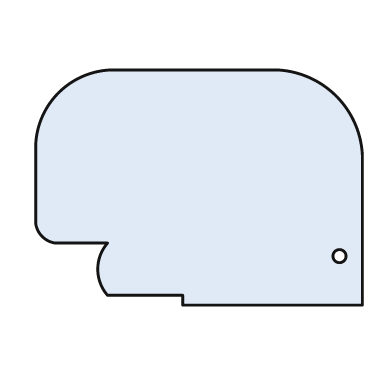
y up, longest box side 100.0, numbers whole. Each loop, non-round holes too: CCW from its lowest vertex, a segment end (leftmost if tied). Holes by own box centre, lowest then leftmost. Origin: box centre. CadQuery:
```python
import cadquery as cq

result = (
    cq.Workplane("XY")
    .moveTo(-5.0, -36.0)
    .lineTo(50.0, -36.0)
    .lineTo(50.0, 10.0)
    .threePointArc((42.0, 28.0), (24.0, 36.0))
    .lineTo(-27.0, 36.0)
    .threePointArc((-43.0, 29.0), (-50.0, 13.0))
    .lineTo(-50.0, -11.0)
    .threePointArc((-48.0, -15.0), (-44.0, -17.0))
    .lineTo(-28.0, -17.0)
    .threePointArc((-31.0, -25.0), (-28.0, -33.0))
    .lineTo(-5.0, -33.0)
    .close()
    .moveTo(43.0, -21.0)
    .circle(2.0)
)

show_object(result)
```